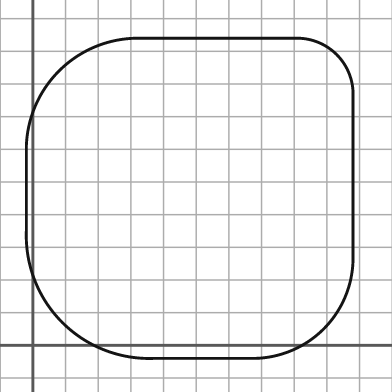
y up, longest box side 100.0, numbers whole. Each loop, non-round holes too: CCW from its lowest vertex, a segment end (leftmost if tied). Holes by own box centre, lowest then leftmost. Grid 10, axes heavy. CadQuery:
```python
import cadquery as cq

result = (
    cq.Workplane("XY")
    .moveTo(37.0, -4.0)
    .lineTo(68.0, -4.0)
    .threePointArc((89.0, 5.0), (98.0, 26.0))
    .lineTo(98.0, 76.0)
    .threePointArc((93.0, 89.0), (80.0, 94.0))
    .lineTo(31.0, 94.0)
    .threePointArc((8.0, 84.0), (-2.0, 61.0))
    .lineTo(-2.0, 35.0)
    .threePointArc((9.0, 7.0), (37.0, -4.0))
    .close()
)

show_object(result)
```